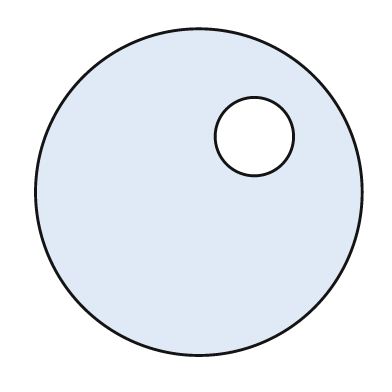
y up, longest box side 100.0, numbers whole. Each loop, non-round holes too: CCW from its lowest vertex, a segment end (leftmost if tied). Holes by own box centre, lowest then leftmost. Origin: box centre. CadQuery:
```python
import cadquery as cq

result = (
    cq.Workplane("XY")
    .moveTo(0.0, 0.0)
    .circle(50.0)
    .moveTo(17.0, 17.0)
    .circle(12.0)
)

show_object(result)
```